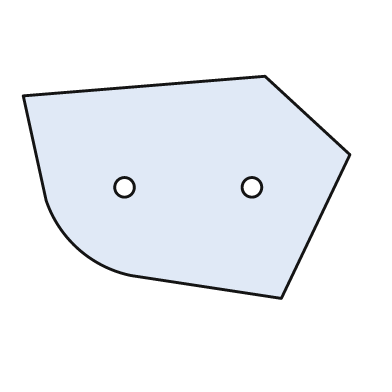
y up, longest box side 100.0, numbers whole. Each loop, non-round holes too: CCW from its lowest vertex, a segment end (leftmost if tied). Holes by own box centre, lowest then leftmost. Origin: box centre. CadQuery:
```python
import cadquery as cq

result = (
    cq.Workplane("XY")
    .moveTo(29.0, -34.0)
    .lineTo(50.0, 10.0)
    .lineTo(24.0, 34.0)
    .lineTo(-50.0, 28.0)
    .lineTo(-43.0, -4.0)
    .threePointArc((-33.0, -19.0), (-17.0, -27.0))
    .close()
    .moveTo(-19.0, 0.0)
    .circle(3.0)
    .moveTo(20.0, 0.0)
    .circle(3.0)
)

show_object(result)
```